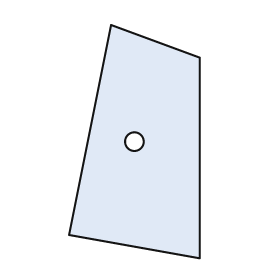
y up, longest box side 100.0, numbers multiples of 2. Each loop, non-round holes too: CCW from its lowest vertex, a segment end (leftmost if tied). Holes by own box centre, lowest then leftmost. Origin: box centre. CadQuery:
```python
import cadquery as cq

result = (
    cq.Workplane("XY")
    .moveTo(28.0, -50.0)
    .lineTo(28.0, 36.0)
    .lineTo(-10.0, 50.0)
    .lineTo(-28.0, -40.0)
    .close()
    .moveTo(0.0, 0.0)
    .circle(4.0)
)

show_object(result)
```